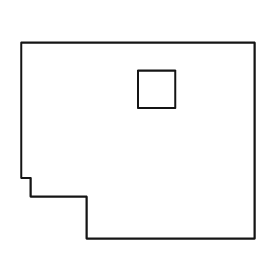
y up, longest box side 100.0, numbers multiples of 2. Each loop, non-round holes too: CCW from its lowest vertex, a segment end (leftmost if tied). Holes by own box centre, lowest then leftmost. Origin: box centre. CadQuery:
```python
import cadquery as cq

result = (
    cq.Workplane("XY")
    .moveTo(-22.0, -42.0)
    .lineTo(50.0, -42.0)
    .lineTo(50.0, 42.0)
    .lineTo(-50.0, 42.0)
    .lineTo(-50.0, -16.0)
    .lineTo(-46.0, -16.0)
    .lineTo(-46.0, -24.0)
    .lineTo(-22.0, -24.0)
    .close()
    .moveTo(0.0, 14.0)
    .lineTo(16.0, 14.0)
    .lineTo(16.0, 30.0)
    .lineTo(0.0, 30.0)
    .close()
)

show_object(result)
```